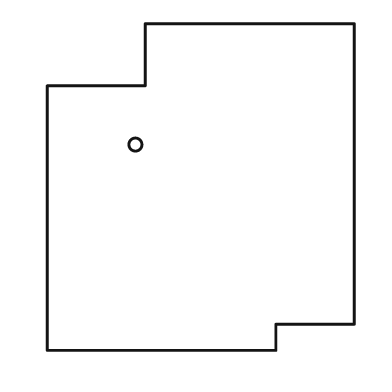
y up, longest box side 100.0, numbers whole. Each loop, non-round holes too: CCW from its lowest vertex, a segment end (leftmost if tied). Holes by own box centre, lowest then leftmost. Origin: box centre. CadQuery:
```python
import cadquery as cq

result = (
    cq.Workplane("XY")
    .moveTo(-47.0, -50.0)
    .lineTo(23.0, -50.0)
    .lineTo(23.0, -42.0)
    .lineTo(47.0, -42.0)
    .lineTo(47.0, 50.0)
    .lineTo(-17.0, 50.0)
    .lineTo(-17.0, 31.0)
    .lineTo(-47.0, 31.0)
    .close()
    .moveTo(-20.0, 13.0)
    .circle(2.0)
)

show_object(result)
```